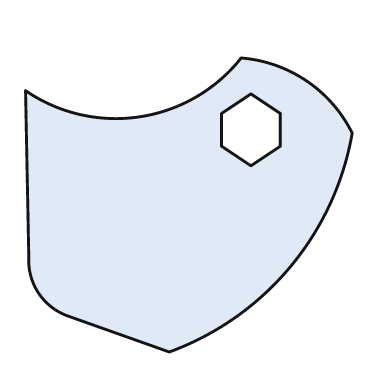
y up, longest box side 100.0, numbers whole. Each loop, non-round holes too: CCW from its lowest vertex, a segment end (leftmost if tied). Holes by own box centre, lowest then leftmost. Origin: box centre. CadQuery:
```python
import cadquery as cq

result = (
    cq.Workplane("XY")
    .moveTo(-6.0, -45.0)
    .threePointArc((31.0, -19.0), (50.0, 22.0))
    .threePointArc((36.0, 38.0), (16.0, 45.0))
    .threePointArc((-15.0, 27.0), (-50.0, 35.0))
    .lineTo(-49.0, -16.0)
    .threePointArc((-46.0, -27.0), (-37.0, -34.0))
    .close()
    .moveTo(19.0, 12.0)
    .lineTo(28.0, 18.0)
    .lineTo(28.0, 28.0)
    .lineTo(19.0, 34.0)
    .lineTo(10.0, 28.0)
    .lineTo(10.0, 18.0)
    .close()
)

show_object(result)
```